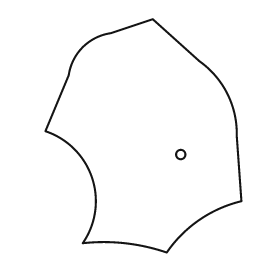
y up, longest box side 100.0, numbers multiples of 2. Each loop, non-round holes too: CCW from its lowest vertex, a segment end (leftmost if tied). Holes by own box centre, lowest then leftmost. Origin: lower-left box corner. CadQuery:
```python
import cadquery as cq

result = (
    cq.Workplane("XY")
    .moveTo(52.0, 0.0)
    .threePointArc((66.0, 14.0), (84.0, 22.0))
    .lineTo(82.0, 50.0)
    .threePointArc((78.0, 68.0), (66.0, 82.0))
    .lineTo(46.0, 100.0)
    .lineTo(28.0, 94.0)
    .threePointArc((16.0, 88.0), (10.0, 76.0))
    .lineTo(0.0, 52.0)
    .threePointArc((20.0, 32.0), (16.0, 4.0))
    .threePointArc((34.0, 4.0), (52.0, 0.0))
    .close()
    .moveTo(58.0, 42.0)
    .circle(2.0)
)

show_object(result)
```